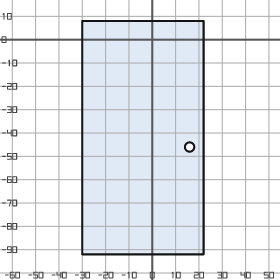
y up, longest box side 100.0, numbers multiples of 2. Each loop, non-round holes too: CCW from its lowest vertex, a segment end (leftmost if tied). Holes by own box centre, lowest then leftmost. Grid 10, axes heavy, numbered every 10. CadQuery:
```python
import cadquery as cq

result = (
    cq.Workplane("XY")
    .moveTo(-30.0, -92.0)
    .lineTo(22.0, -92.0)
    .lineTo(22.0, 8.0)
    .lineTo(-30.0, 8.0)
    .close()
    .moveTo(16.0, -46.0)
    .circle(2.0)
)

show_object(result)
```